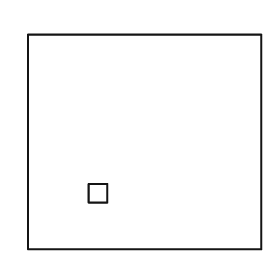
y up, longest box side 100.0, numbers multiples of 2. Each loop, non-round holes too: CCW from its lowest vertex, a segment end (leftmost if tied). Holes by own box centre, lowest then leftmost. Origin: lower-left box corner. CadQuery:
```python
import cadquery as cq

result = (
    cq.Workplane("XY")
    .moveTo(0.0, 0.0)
    .lineTo(100.0, 0.0)
    .lineTo(100.0, 92.0)
    .lineTo(0.0, 92.0)
    .close()
    .moveTo(26.0, 20.0)
    .lineTo(34.0, 20.0)
    .lineTo(34.0, 28.0)
    .lineTo(26.0, 28.0)
    .close()
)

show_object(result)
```